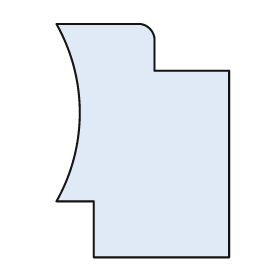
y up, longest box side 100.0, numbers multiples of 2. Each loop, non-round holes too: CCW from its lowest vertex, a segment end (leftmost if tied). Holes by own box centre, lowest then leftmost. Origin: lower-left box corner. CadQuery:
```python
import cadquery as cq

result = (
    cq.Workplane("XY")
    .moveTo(16.0, 0.0)
    .lineTo(74.0, 0.0)
    .lineTo(74.0, 80.0)
    .lineTo(42.0, 80.0)
    .lineTo(42.0, 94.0)
    .threePointArc((40.0, 98.0), (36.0, 100.0))
    .lineTo(0.0, 100.0)
    .threePointArc((10.0, 62.0), (0.0, 24.0))
    .lineTo(16.0, 24.0)
    .close()
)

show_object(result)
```